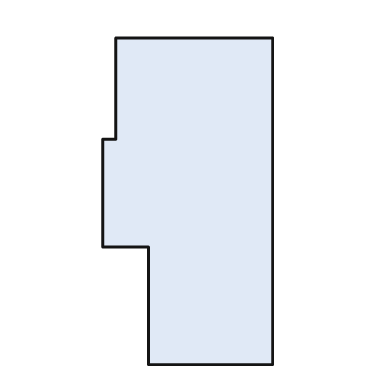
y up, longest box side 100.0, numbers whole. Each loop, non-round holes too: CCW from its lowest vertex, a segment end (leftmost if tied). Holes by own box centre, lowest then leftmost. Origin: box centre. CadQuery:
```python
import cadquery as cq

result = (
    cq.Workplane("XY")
    .moveTo(-12.0, -50.0)
    .lineTo(26.0, -50.0)
    .lineTo(26.0, 50.0)
    .lineTo(-22.0, 50.0)
    .lineTo(-22.0, 19.0)
    .lineTo(-26.0, 19.0)
    .lineTo(-26.0, -14.0)
    .lineTo(-12.0, -14.0)
    .close()
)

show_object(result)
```